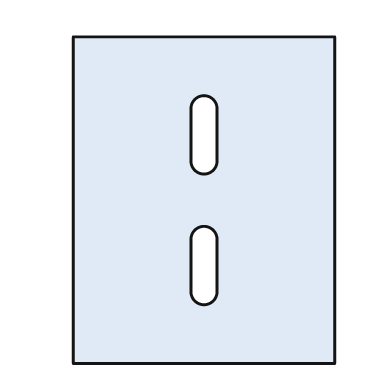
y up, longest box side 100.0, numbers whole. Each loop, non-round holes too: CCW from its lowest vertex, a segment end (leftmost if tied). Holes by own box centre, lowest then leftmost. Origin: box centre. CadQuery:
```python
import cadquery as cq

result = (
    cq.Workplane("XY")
    .moveTo(-40.0, -50.0)
    .lineTo(40.0, -50.0)
    .lineTo(40.0, 50.0)
    .lineTo(-40.0, 50.0)
    .close()
    .moveTo(-4.0, -28.0)
    .threePointArc((0.0, -32.0), (4.0, -28.0))
    .lineTo(4.0, -12.0)
    .threePointArc((0.0, -8.0), (-4.0, -12.0))
    .close()
    .moveTo(-4.0, 12.0)
    .threePointArc((0.0, 8.0), (4.0, 12.0))
    .lineTo(4.0, 28.0)
    .threePointArc((0.0, 32.0), (-4.0, 28.0))
    .close()
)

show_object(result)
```